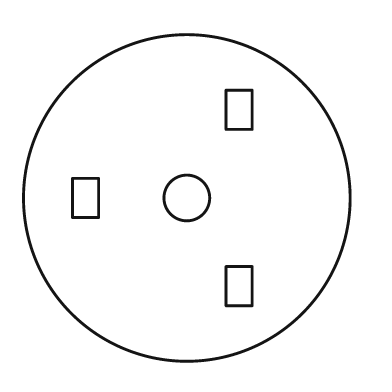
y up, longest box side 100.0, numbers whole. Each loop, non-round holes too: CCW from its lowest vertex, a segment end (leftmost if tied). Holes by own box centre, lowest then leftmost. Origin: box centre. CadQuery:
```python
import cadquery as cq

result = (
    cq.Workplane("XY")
    .moveTo(0.0, 0.0)
    .circle(50.0)
    .moveTo(12.0, -33.0)
    .lineTo(20.0, -33.0)
    .lineTo(20.0, -21.0)
    .lineTo(12.0, -21.0)
    .close()
    .moveTo(-35.0, -6.0)
    .lineTo(-27.0, -6.0)
    .lineTo(-27.0, 6.0)
    .lineTo(-35.0, 6.0)
    .close()
    .moveTo(0.0, 0.0)
    .circle(7.0)
    .moveTo(12.0, 21.0)
    .lineTo(20.0, 21.0)
    .lineTo(20.0, 33.0)
    .lineTo(12.0, 33.0)
    .close()
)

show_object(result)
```